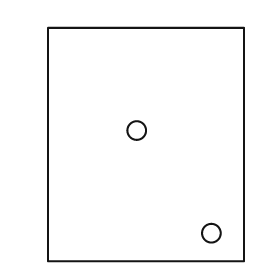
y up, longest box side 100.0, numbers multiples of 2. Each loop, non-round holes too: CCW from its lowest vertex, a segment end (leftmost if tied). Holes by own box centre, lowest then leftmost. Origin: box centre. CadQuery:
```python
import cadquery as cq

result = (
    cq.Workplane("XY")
    .moveTo(-42.0, -50.0)
    .lineTo(42.0, -50.0)
    .lineTo(42.0, 50.0)
    .lineTo(-42.0, 50.0)
    .close()
    .moveTo(28.0, -38.0)
    .circle(4.0)
    .moveTo(-4.0, 6.0)
    .circle(4.0)
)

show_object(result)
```